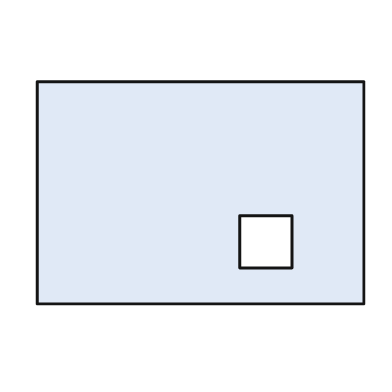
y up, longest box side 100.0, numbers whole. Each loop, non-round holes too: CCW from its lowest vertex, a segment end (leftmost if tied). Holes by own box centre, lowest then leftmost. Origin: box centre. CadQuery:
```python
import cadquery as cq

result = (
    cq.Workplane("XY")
    .moveTo(-50.0, -34.0)
    .lineTo(50.0, -34.0)
    .lineTo(50.0, 34.0)
    .lineTo(-50.0, 34.0)
    .close()
    .moveTo(12.0, -23.0)
    .lineTo(28.0, -23.0)
    .lineTo(28.0, -7.0)
    .lineTo(12.0, -7.0)
    .close()
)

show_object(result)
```